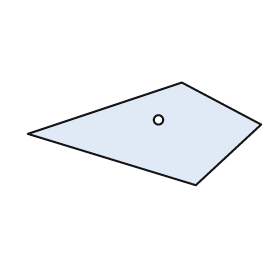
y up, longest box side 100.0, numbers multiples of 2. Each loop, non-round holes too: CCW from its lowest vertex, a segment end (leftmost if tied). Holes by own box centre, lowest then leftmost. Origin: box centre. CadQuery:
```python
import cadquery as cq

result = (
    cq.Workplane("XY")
    .moveTo(22.0, -22.0)
    .lineTo(50.0, 4.0)
    .lineTo(16.0, 22.0)
    .lineTo(-50.0, 0.0)
    .close()
    .moveTo(6.0, 6.0)
    .circle(2.0)
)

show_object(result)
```